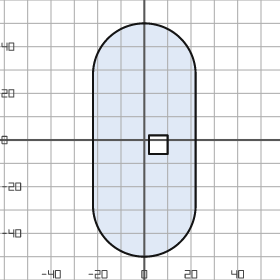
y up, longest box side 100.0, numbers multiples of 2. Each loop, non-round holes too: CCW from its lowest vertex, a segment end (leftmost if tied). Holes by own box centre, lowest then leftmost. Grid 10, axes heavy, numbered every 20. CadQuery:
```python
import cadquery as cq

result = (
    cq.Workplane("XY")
    .moveTo(-22.0, -28.0)
    .threePointArc((0.0, -50.0), (22.0, -28.0))
    .lineTo(22.0, 28.0)
    .threePointArc((0.0, 50.0), (-22.0, 28.0))
    .close()
    .moveTo(2.0, -6.0)
    .lineTo(10.0, -6.0)
    .lineTo(10.0, 2.0)
    .lineTo(2.0, 2.0)
    .close()
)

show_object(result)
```